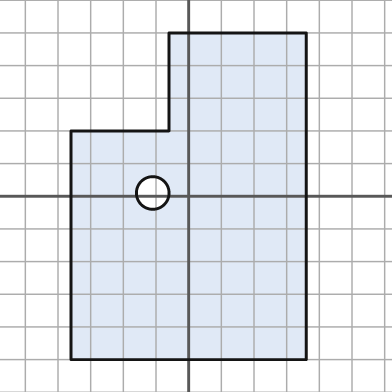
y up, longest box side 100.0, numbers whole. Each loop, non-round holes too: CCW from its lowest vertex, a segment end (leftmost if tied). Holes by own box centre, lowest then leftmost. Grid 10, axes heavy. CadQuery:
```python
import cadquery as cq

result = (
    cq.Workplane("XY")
    .moveTo(-36.0, -50.0)
    .lineTo(36.0, -50.0)
    .lineTo(36.0, 50.0)
    .lineTo(-6.0, 50.0)
    .lineTo(-6.0, 20.0)
    .lineTo(-36.0, 20.0)
    .close()
    .moveTo(-11.0, 1.0)
    .circle(5.0)
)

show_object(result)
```